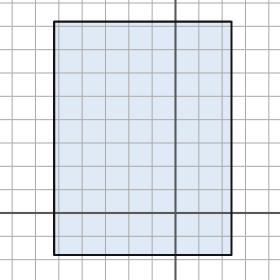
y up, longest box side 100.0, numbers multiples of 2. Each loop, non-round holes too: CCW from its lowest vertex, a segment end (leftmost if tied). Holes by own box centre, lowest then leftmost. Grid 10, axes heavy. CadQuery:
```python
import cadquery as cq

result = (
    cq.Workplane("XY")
    .moveTo(-52.0, -18.0)
    .lineTo(24.0, -18.0)
    .lineTo(24.0, 82.0)
    .lineTo(-52.0, 82.0)
    .close()
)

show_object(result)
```